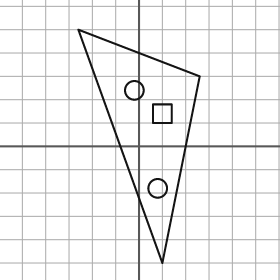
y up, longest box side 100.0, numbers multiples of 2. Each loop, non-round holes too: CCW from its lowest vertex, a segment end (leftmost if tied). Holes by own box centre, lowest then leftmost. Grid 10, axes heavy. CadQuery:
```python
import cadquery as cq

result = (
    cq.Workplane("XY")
    .moveTo(10.0, -50.0)
    .lineTo(26.0, 30.0)
    .lineTo(-26.0, 50.0)
    .close()
    .moveTo(8.0, -18.0)
    .circle(4.0)
    .moveTo(6.0, 10.0)
    .lineTo(14.0, 10.0)
    .lineTo(14.0, 18.0)
    .lineTo(6.0, 18.0)
    .close()
    .moveTo(-2.0, 24.0)
    .circle(4.0)
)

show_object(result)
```